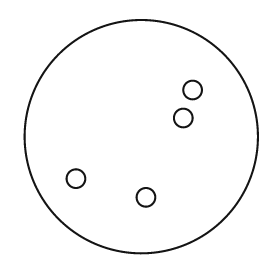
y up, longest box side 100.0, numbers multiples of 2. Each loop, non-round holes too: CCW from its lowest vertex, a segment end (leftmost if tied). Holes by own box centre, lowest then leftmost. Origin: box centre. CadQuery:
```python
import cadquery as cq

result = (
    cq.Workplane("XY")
    .moveTo(0.0, 0.0)
    .circle(50.0)
    .moveTo(2.0, -26.0)
    .circle(4.0)
    .moveTo(-28.0, -18.0)
    .circle(4.0)
    .moveTo(18.0, 8.0)
    .circle(4.0)
    .moveTo(22.0, 20.0)
    .circle(4.0)
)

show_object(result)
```